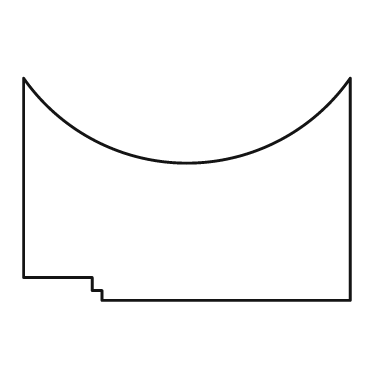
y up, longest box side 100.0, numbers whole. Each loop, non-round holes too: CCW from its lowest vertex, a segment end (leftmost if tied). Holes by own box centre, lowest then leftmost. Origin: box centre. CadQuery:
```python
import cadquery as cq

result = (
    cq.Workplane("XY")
    .moveTo(-26.0, -34.0)
    .lineTo(50.0, -34.0)
    .lineTo(50.0, 34.0)
    .threePointArc((0.0, 8.0), (-50.0, 34.0))
    .lineTo(-50.0, -27.0)
    .lineTo(-29.0, -27.0)
    .lineTo(-29.0, -31.0)
    .lineTo(-26.0, -31.0)
    .close()
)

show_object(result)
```